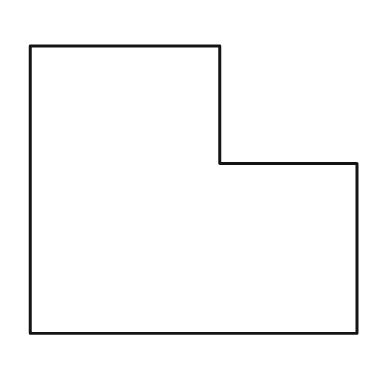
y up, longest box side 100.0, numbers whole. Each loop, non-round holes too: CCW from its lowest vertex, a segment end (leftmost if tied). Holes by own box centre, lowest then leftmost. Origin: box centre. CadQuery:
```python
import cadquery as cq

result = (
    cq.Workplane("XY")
    .moveTo(-50.0, -44.0)
    .lineTo(50.0, -44.0)
    .lineTo(50.0, 8.0)
    .lineTo(8.0, 8.0)
    .lineTo(8.0, 44.0)
    .lineTo(-50.0, 44.0)
    .close()
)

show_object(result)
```